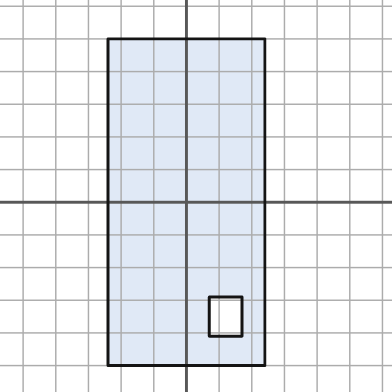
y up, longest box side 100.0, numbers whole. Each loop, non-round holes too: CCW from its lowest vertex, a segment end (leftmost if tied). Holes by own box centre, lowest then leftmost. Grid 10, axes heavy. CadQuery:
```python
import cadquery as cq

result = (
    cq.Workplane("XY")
    .moveTo(-24.0, -50.0)
    .lineTo(24.0, -50.0)
    .lineTo(24.0, 50.0)
    .lineTo(-24.0, 50.0)
    .close()
    .moveTo(7.0, -41.0)
    .lineTo(17.0, -41.0)
    .lineTo(17.0, -29.0)
    .lineTo(7.0, -29.0)
    .close()
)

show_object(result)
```